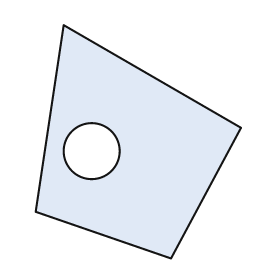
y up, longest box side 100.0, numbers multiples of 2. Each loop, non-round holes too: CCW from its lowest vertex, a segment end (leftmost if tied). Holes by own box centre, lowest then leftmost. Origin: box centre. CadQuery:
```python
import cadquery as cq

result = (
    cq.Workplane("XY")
    .moveTo(14.0, -50.0)
    .lineTo(44.0, 6.0)
    .lineTo(-32.0, 50.0)
    .lineTo(-44.0, -30.0)
    .close()
    .moveTo(-20.0, -4.0)
    .circle(12.0)
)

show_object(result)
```